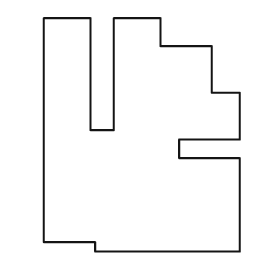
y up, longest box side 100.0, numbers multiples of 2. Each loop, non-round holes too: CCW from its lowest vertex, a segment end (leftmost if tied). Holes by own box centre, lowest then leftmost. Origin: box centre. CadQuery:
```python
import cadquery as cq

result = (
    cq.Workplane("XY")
    .moveTo(-20.0, -50.0)
    .lineTo(42.0, -50.0)
    .lineTo(42.0, -10.0)
    .lineTo(16.0, -10.0)
    .lineTo(16.0, -2.0)
    .lineTo(42.0, -2.0)
    .lineTo(42.0, 18.0)
    .lineTo(30.0, 18.0)
    .lineTo(30.0, 38.0)
    .lineTo(8.0, 38.0)
    .lineTo(8.0, 50.0)
    .lineTo(-12.0, 50.0)
    .lineTo(-12.0, 2.0)
    .lineTo(-22.0, 2.0)
    .lineTo(-22.0, 50.0)
    .lineTo(-42.0, 50.0)
    .lineTo(-42.0, -46.0)
    .lineTo(-20.0, -46.0)
    .close()
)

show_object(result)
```